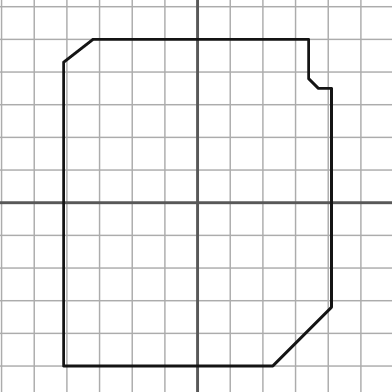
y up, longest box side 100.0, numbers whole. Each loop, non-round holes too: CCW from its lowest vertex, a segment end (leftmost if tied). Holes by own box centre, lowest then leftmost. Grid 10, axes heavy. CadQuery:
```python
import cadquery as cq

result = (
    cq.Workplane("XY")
    .moveTo(-41.0, -50.0)
    .lineTo(23.0, -50.0)
    .lineTo(41.0, -32.0)
    .lineTo(41.0, 35.0)
    .lineTo(37.0, 35.0)
    .lineTo(34.0, 38.0)
    .lineTo(34.0, 50.0)
    .lineTo(-32.0, 50.0)
    .lineTo(-41.0, 43.0)
    .close()
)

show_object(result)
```